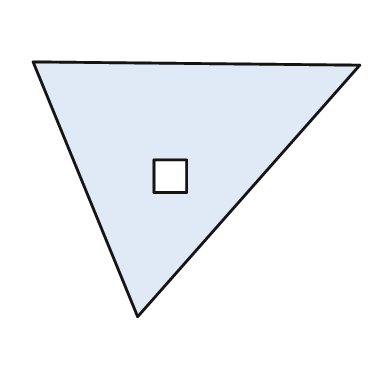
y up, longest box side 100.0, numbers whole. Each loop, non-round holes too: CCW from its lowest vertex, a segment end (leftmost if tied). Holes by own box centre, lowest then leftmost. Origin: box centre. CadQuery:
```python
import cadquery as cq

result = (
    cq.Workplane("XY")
    .moveTo(-18.0, -39.0)
    .lineTo(50.0, 38.0)
    .lineTo(-50.0, 39.0)
    .close()
    .moveTo(-13.0, -1.0)
    .lineTo(-3.0, -1.0)
    .lineTo(-3.0, 9.0)
    .lineTo(-13.0, 9.0)
    .close()
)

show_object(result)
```